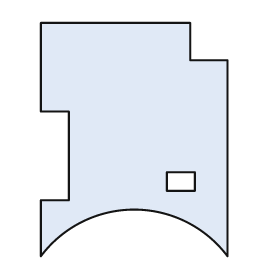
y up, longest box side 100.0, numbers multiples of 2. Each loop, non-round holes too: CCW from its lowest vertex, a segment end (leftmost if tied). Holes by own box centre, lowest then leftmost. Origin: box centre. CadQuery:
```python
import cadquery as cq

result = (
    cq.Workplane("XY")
    .moveTo(-40.0, -50.0)
    .threePointArc((0.0, -30.0), (40.0, -50.0))
    .lineTo(40.0, 34.0)
    .lineTo(24.0, 34.0)
    .lineTo(24.0, 50.0)
    .lineTo(-40.0, 50.0)
    .lineTo(-40.0, 12.0)
    .lineTo(-28.0, 12.0)
    .lineTo(-28.0, -26.0)
    .lineTo(-40.0, -26.0)
    .close()
    .moveTo(14.0, -22.0)
    .lineTo(26.0, -22.0)
    .lineTo(26.0, -14.0)
    .lineTo(14.0, -14.0)
    .close()
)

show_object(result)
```